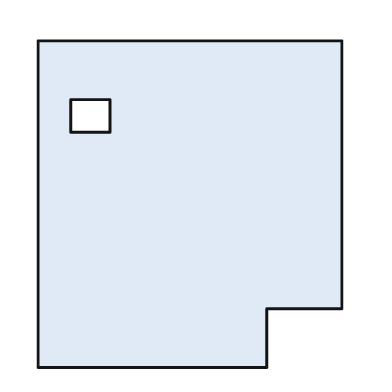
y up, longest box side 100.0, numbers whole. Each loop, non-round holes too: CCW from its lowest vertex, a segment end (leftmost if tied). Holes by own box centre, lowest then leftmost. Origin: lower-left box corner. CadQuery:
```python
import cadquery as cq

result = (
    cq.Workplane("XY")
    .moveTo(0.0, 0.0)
    .lineTo(70.0, 0.0)
    .lineTo(70.0, 18.0)
    .lineTo(93.0, 18.0)
    .lineTo(93.0, 100.0)
    .lineTo(0.0, 100.0)
    .close()
    .moveTo(10.0, 72.0)
    .lineTo(22.0, 72.0)
    .lineTo(22.0, 82.0)
    .lineTo(10.0, 82.0)
    .close()
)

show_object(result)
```